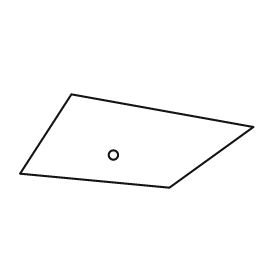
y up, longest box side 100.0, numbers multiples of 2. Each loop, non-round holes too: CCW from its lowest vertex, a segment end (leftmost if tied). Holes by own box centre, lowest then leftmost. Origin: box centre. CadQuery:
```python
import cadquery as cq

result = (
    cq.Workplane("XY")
    .moveTo(14.0, -20.0)
    .lineTo(50.0, 6.0)
    .lineTo(-28.0, 20.0)
    .lineTo(-50.0, -14.0)
    .close()
    .moveTo(-10.0, -6.0)
    .circle(2.0)
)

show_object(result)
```